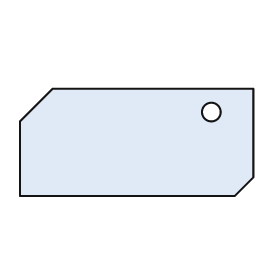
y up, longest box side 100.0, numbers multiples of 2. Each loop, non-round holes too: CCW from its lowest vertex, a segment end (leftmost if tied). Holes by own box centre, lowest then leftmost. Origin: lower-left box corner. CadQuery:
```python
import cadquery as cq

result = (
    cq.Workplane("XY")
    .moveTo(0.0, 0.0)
    .lineTo(92.0, 0.0)
    .lineTo(100.0, 8.0)
    .lineTo(100.0, 46.0)
    .lineTo(14.0, 46.0)
    .lineTo(0.0, 32.0)
    .close()
    .moveTo(82.0, 36.0)
    .circle(4.0)
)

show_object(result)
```